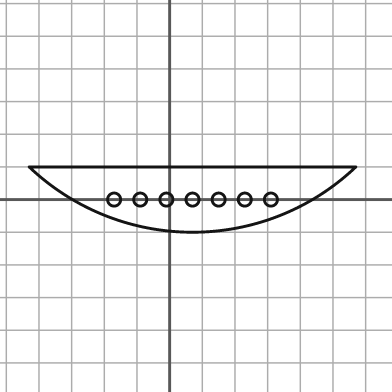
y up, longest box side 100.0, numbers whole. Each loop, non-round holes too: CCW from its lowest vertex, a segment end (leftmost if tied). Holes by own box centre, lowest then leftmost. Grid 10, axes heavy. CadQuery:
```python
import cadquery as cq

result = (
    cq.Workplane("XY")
    .moveTo(-43.0, 10.0)
    .threePointArc((7.0, -10.0), (57.0, 10.0))
    .close()
    .moveTo(-17.0, 0.0)
    .circle(2.0)
    .moveTo(-9.0, 0.0)
    .circle(2.0)
    .moveTo(-1.0, 0.0)
    .circle(2.0)
    .moveTo(7.0, 0.0)
    .circle(2.0)
    .moveTo(15.0, 0.0)
    .circle(2.0)
    .moveTo(23.0, 0.0)
    .circle(2.0)
    .moveTo(31.0, 0.0)
    .circle(2.0)
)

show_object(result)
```